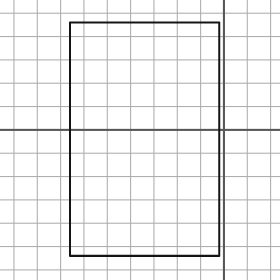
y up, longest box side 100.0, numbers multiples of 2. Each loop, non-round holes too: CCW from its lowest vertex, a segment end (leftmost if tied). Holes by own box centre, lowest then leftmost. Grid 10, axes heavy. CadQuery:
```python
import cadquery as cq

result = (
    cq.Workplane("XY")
    .moveTo(-66.0, -54.0)
    .lineTo(-2.0, -54.0)
    .lineTo(-2.0, 46.0)
    .lineTo(-66.0, 46.0)
    .close()
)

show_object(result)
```